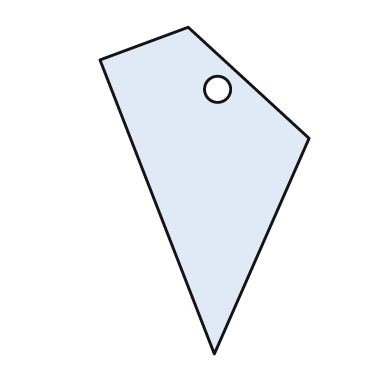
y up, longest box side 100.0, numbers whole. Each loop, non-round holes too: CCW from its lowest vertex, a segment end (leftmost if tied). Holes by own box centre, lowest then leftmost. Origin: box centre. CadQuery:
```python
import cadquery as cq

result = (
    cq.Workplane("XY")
    .moveTo(3.0, -50.0)
    .lineTo(32.0, 16.0)
    .lineTo(-5.0, 50.0)
    .lineTo(-32.0, 40.0)
    .close()
    .moveTo(4.0, 31.0)
    .circle(4.0)
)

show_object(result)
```